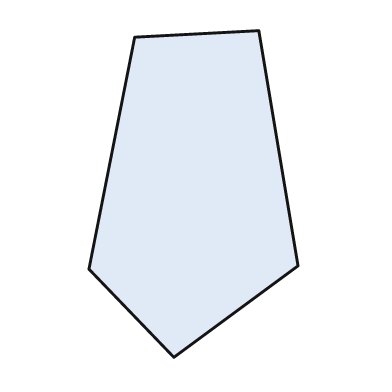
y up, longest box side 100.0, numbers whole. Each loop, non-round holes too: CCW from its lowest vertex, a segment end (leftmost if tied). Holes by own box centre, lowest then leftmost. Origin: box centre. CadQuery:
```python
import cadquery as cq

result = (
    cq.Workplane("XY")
    .moveTo(-6.0, -50.0)
    .lineTo(32.0, -22.0)
    .lineTo(20.0, 50.0)
    .lineTo(-18.0, 48.0)
    .lineTo(-32.0, -23.0)
    .close()
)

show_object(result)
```